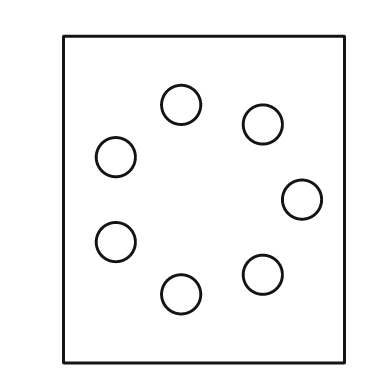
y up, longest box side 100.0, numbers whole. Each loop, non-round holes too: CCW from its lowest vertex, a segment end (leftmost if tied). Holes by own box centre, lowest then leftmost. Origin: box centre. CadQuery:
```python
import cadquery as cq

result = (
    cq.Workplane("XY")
    .moveTo(-43.0, -50.0)
    .lineTo(43.0, -50.0)
    .lineTo(43.0, 50.0)
    .lineTo(-43.0, 50.0)
    .close()
    .moveTo(-7.0, -29.0)
    .circle(6.0)
    .moveTo(18.0, -23.0)
    .circle(6.0)
    .moveTo(-27.0, -13.0)
    .circle(6.0)
    .moveTo(30.0, 0.0)
    .circle(6.0)
    .moveTo(-27.0, 13.0)
    .circle(6.0)
    .moveTo(18.0, 23.0)
    .circle(6.0)
    .moveTo(-7.0, 29.0)
    .circle(6.0)
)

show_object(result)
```